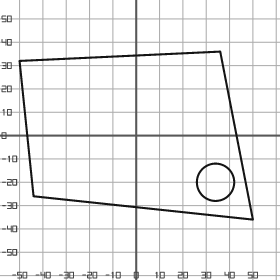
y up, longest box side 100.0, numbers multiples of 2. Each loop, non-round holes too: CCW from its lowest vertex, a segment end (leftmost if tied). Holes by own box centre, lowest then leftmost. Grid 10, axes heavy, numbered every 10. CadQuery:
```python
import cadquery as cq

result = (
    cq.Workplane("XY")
    .moveTo(50.0, -36.0)
    .lineTo(36.0, 36.0)
    .lineTo(-50.0, 32.0)
    .lineTo(-44.0, -26.0)
    .close()
    .moveTo(34.0, -20.0)
    .circle(8.0)
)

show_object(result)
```